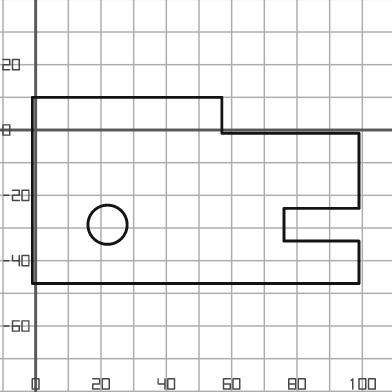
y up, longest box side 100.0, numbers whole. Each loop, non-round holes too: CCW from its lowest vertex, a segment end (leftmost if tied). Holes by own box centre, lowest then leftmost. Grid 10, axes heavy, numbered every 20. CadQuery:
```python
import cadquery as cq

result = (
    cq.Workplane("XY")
    .moveTo(-1.0, -47.0)
    .lineTo(99.0, -47.0)
    .lineTo(99.0, -34.0)
    .lineTo(76.0, -34.0)
    .lineTo(76.0, -24.0)
    .lineTo(99.0, -24.0)
    .lineTo(99.0, -1.0)
    .lineTo(57.0, -1.0)
    .lineTo(57.0, 10.0)
    .lineTo(-1.0, 10.0)
    .close()
    .moveTo(22.0, -29.0)
    .circle(6.0)
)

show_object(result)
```